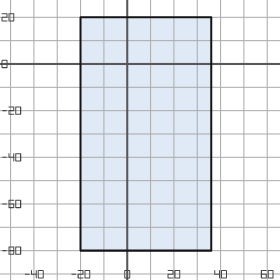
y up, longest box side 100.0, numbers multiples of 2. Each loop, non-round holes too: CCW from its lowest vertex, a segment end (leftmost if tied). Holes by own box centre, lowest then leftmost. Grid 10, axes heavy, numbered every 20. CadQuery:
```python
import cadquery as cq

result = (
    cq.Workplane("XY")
    .moveTo(-20.0, -80.0)
    .lineTo(36.0, -80.0)
    .lineTo(36.0, 20.0)
    .lineTo(-20.0, 20.0)
    .close()
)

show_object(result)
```